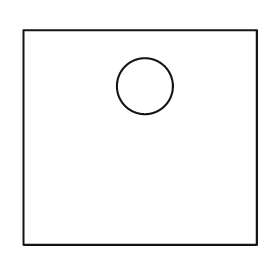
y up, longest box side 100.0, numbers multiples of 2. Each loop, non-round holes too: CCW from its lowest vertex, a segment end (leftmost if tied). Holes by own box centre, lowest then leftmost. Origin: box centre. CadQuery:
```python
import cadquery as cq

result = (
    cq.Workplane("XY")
    .moveTo(-50.0, -46.0)
    .lineTo(50.0, -46.0)
    .lineTo(50.0, 46.0)
    .lineTo(-50.0, 46.0)
    .close()
    .moveTo(2.0, 22.0)
    .circle(12.0)
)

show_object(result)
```